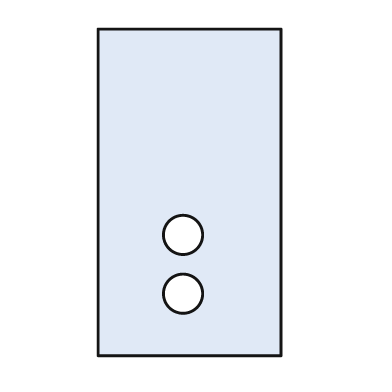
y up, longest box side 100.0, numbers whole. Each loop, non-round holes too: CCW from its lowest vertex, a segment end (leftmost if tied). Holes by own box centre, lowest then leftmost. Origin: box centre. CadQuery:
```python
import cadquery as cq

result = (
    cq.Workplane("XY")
    .moveTo(-28.0, -50.0)
    .lineTo(28.0, -50.0)
    .lineTo(28.0, 50.0)
    .lineTo(-28.0, 50.0)
    .close()
    .moveTo(-2.0, -31.0)
    .circle(6.0)
    .moveTo(-2.0, -13.0)
    .circle(6.0)
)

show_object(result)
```